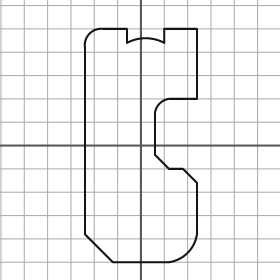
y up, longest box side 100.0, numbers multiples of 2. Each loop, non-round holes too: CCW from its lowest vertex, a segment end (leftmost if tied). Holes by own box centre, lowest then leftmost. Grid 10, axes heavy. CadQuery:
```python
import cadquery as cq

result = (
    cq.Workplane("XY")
    .moveTo(-12.0, -50.0)
    .lineTo(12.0, -50.0)
    .threePointArc((20.0, -46.0), (24.0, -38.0))
    .lineTo(24.0, -16.0)
    .lineTo(18.0, -10.0)
    .lineTo(12.0, -10.0)
    .lineTo(6.0, -4.0)
    .lineTo(6.0, 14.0)
    .threePointArc((8.0, 18.0), (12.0, 20.0))
    .lineTo(24.0, 20.0)
    .lineTo(24.0, 50.0)
    .lineTo(10.0, 50.0)
    .lineTo(10.0, 44.0)
    .threePointArc((2.0, 46.0), (-6.0, 44.0))
    .lineTo(-6.0, 50.0)
    .lineTo(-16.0, 50.0)
    .threePointArc((-22.0, 48.0), (-24.0, 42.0))
    .lineTo(-24.0, -38.0)
    .close()
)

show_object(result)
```